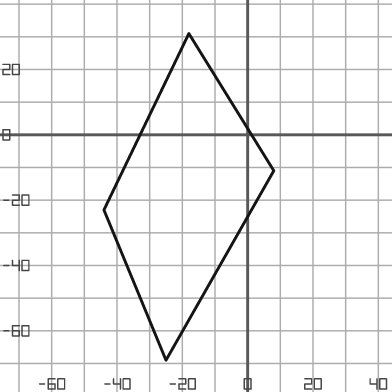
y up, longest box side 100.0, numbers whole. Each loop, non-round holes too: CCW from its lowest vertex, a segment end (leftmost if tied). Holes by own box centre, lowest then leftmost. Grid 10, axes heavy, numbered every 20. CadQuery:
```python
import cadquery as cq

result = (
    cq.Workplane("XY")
    .moveTo(-25.0, -69.0)
    .lineTo(8.0, -11.0)
    .lineTo(-18.0, 31.0)
    .lineTo(-44.0, -23.0)
    .close()
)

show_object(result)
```